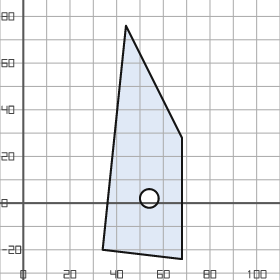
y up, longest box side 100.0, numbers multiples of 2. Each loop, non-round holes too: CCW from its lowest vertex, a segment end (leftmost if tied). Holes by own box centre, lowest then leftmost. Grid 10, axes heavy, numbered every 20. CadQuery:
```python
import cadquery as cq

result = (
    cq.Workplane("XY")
    .moveTo(68.0, -24.0)
    .lineTo(68.0, 28.0)
    .lineTo(44.0, 76.0)
    .lineTo(34.0, -20.0)
    .close()
    .moveTo(54.0, 2.0)
    .circle(4.0)
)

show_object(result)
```